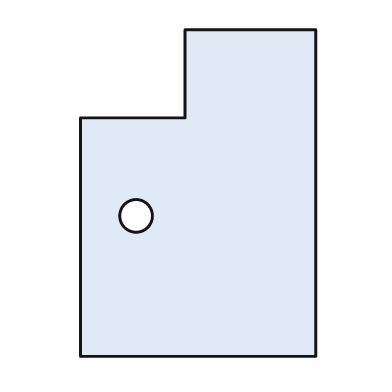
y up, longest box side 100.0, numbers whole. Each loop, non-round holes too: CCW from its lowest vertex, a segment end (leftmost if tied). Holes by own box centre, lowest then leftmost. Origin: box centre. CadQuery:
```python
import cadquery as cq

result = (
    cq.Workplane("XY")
    .moveTo(-36.0, -50.0)
    .lineTo(36.0, -50.0)
    .lineTo(36.0, 50.0)
    .lineTo(-4.0, 50.0)
    .lineTo(-4.0, 23.0)
    .lineTo(-36.0, 23.0)
    .close()
    .moveTo(-19.0, -7.0)
    .circle(5.0)
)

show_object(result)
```